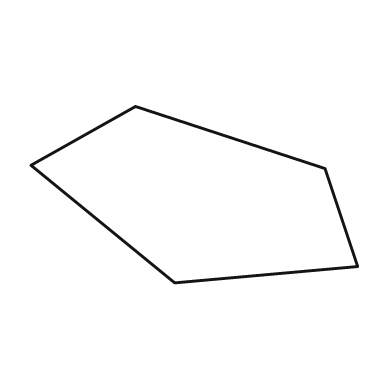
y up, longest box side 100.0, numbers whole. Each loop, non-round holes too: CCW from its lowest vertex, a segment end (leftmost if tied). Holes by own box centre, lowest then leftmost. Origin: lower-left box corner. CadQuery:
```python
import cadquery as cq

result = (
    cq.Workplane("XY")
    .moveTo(44.0, 0.0)
    .lineTo(100.0, 5.0)
    .lineTo(90.0, 35.0)
    .lineTo(32.0, 54.0)
    .lineTo(0.0, 36.0)
    .close()
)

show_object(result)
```